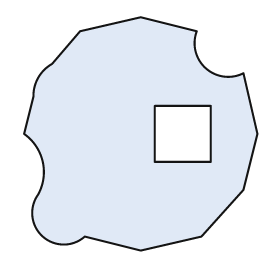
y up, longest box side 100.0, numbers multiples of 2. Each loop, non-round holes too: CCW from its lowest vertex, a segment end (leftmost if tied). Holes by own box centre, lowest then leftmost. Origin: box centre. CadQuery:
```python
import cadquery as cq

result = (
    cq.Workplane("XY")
    .moveTo(0.0, -50.0)
    .lineTo(26.0, -44.0)
    .lineTo(44.0, -24.0)
    .lineTo(50.0, 0.0)
    .lineTo(44.0, 26.0)
    .threePointArc((28.0, 28.0), (24.0, 44.0))
    .lineTo(0.0, 50.0)
    .lineTo(-26.0, 44.0)
    .lineTo(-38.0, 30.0)
    .threePointArc((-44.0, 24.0), (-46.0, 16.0))
    .lineTo(-50.0, 0.0)
    .threePointArc((-42.0, -12.0), (-44.0, -26.0))
    .threePointArc((-42.0, -44.0), (-24.0, -44.0))
    .close()
    .moveTo(6.0, -12.0)
    .lineTo(30.0, -12.0)
    .lineTo(30.0, 12.0)
    .lineTo(6.0, 12.0)
    .close()
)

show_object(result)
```